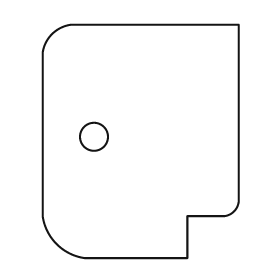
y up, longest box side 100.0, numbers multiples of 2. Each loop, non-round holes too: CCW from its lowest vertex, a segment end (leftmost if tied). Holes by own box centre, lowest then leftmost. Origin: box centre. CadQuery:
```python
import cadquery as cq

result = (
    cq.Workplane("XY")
    .moveTo(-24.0, -50.0)
    .lineTo(20.0, -50.0)
    .lineTo(20.0, -32.0)
    .lineTo(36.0, -32.0)
    .threePointArc((40.0, -30.0), (42.0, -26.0))
    .lineTo(42.0, 50.0)
    .lineTo(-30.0, 50.0)
    .threePointArc((-38.0, 46.0), (-42.0, 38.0))
    .lineTo(-42.0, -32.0)
    .threePointArc((-36.0, -44.0), (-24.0, -50.0))
    .close()
    .moveTo(-20.0, 2.0)
    .circle(6.0)
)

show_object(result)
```